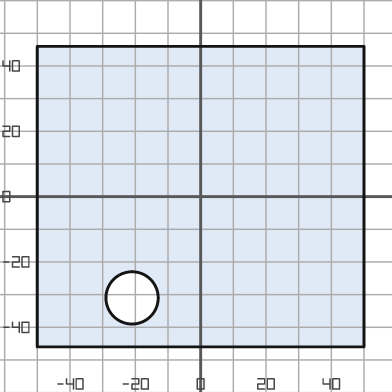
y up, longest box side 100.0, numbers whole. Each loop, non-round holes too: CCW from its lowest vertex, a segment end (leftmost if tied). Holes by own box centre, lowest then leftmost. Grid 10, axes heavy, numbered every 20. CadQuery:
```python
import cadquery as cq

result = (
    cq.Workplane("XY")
    .moveTo(-50.0, -46.0)
    .lineTo(50.0, -46.0)
    .lineTo(50.0, 46.0)
    .lineTo(-50.0, 46.0)
    .close()
    .moveTo(-21.0, -31.0)
    .circle(8.0)
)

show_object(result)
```